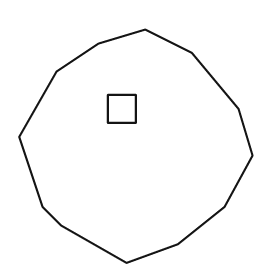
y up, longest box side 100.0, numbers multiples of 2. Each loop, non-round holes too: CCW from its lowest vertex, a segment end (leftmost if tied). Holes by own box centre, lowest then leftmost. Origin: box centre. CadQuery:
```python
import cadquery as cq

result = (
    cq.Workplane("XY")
    .moveTo(-4.0, -50.0)
    .lineTo(18.0, -42.0)
    .lineTo(38.0, -26.0)
    .lineTo(50.0, -4.0)
    .lineTo(44.0, 16.0)
    .lineTo(24.0, 40.0)
    .lineTo(4.0, 50.0)
    .lineTo(-16.0, 44.0)
    .lineTo(-34.0, 32.0)
    .lineTo(-50.0, 4.0)
    .lineTo(-40.0, -26.0)
    .lineTo(-32.0, -34.0)
    .close()
    .moveTo(-12.0, 10.0)
    .lineTo(0.0, 10.0)
    .lineTo(0.0, 22.0)
    .lineTo(-12.0, 22.0)
    .close()
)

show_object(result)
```